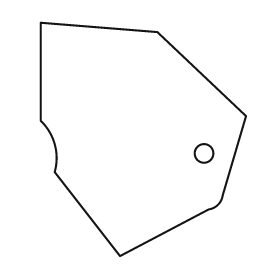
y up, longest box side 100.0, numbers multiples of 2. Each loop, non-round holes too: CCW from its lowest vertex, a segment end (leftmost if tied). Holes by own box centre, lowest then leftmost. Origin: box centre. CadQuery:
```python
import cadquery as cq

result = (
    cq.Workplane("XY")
    .moveTo(-10.0, -50.0)
    .lineTo(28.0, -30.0)
    .threePointArc((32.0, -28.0), (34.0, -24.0))
    .lineTo(44.0, 10.0)
    .lineTo(6.0, 46.0)
    .lineTo(-44.0, 50.0)
    .lineTo(-44.0, 8.0)
    .threePointArc((-38.0, -2.0), (-38.0, -14.0))
    .close()
    .moveTo(26.0, -6.0)
    .circle(4.0)
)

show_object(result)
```